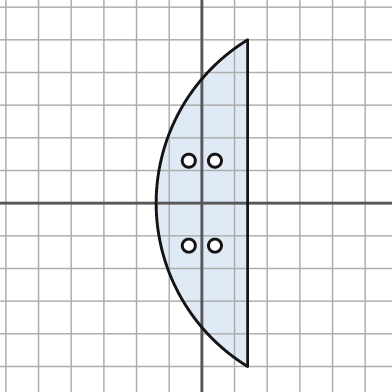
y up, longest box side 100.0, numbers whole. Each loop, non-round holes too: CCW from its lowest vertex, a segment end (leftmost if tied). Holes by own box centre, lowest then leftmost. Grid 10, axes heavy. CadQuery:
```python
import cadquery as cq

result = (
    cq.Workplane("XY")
    .moveTo(14.0, -50.0)
    .lineTo(14.0, 50.0)
    .threePointArc((-14.0, 0.0), (14.0, -50.0))
    .close()
    .moveTo(-4.0, -13.0)
    .circle(2.0)
    .moveTo(4.0, -13.0)
    .circle(2.0)
    .moveTo(-4.0, 13.0)
    .circle(2.0)
    .moveTo(4.0, 13.0)
    .circle(2.0)
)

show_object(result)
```